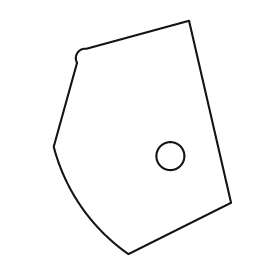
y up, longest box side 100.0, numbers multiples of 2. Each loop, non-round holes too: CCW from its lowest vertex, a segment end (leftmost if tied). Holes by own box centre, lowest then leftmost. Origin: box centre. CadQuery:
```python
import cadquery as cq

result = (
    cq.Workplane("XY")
    .moveTo(-6.0, -50.0)
    .lineTo(38.0, -28.0)
    .lineTo(20.0, 50.0)
    .lineTo(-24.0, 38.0)
    .threePointArc((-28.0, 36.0), (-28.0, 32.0))
    .lineTo(-38.0, -4.0)
    .threePointArc((-26.0, -30.0), (-6.0, -50.0))
    .close()
    .moveTo(12.0, -8.0)
    .circle(6.0)
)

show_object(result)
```